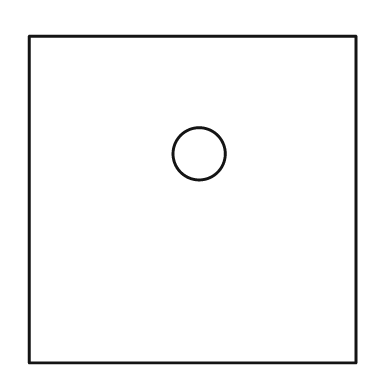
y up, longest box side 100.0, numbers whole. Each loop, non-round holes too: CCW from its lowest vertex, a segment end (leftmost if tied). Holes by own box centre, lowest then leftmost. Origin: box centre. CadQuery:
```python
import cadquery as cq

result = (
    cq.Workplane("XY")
    .moveTo(-50.0, -50.0)
    .lineTo(50.0, -50.0)
    .lineTo(50.0, 50.0)
    .lineTo(-50.0, 50.0)
    .close()
    .moveTo(2.0, 14.0)
    .circle(8.0)
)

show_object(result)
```